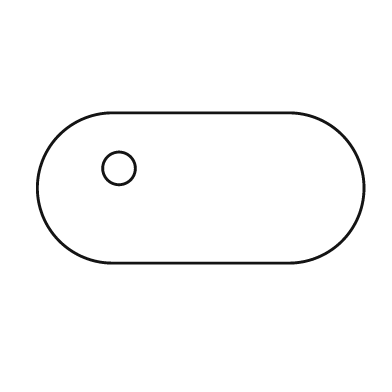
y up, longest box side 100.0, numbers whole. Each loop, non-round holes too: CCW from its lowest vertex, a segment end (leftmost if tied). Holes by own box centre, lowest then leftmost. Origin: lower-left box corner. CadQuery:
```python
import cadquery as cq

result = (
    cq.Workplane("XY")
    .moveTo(23.0, 0.0)
    .lineTo(77.0, 0.0)
    .threePointArc((100.0, 23.0), (77.0, 46.0))
    .lineTo(23.0, 46.0)
    .threePointArc((0.0, 23.0), (23.0, 0.0))
    .close()
    .moveTo(25.0, 29.0)
    .circle(5.0)
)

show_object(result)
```